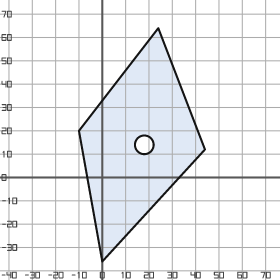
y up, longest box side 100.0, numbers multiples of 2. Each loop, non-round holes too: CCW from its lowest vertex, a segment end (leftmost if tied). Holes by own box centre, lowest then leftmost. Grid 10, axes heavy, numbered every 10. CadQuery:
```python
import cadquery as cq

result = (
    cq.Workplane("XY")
    .moveTo(0.0, -36.0)
    .lineTo(44.0, 12.0)
    .lineTo(24.0, 64.0)
    .lineTo(-10.0, 20.0)
    .close()
    .moveTo(18.0, 14.0)
    .circle(4.0)
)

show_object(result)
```